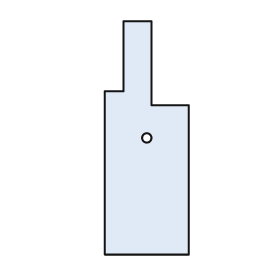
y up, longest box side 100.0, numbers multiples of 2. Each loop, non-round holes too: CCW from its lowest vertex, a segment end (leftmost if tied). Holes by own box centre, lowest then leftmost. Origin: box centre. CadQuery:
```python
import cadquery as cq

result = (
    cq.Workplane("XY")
    .moveTo(-18.0, -50.0)
    .lineTo(18.0, -50.0)
    .lineTo(18.0, 14.0)
    .lineTo(2.0, 14.0)
    .lineTo(2.0, 50.0)
    .lineTo(-10.0, 50.0)
    .lineTo(-10.0, 20.0)
    .lineTo(-18.0, 20.0)
    .close()
    .moveTo(0.0, 0.0)
    .circle(2.0)
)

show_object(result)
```